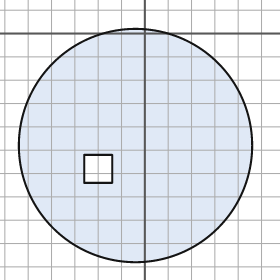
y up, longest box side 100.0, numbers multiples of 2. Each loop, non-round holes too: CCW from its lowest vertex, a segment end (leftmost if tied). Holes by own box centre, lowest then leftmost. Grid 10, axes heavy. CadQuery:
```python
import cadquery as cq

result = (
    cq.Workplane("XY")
    .moveTo(-4.0, -48.0)
    .circle(50.0)
    .moveTo(-26.0, -64.0)
    .lineTo(-14.0, -64.0)
    .lineTo(-14.0, -52.0)
    .lineTo(-26.0, -52.0)
    .close()
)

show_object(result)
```